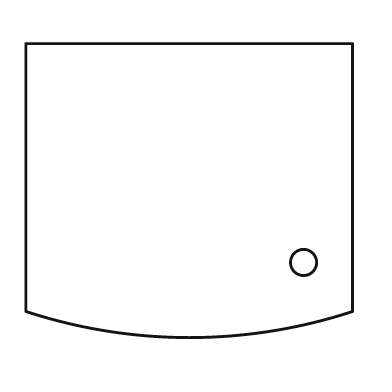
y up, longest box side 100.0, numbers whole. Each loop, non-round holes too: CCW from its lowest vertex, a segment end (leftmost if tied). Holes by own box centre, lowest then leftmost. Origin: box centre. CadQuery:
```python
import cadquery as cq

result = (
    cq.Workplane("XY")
    .moveTo(-50.0, -37.0)
    .threePointArc((0.0, -45.0), (50.0, -37.0))
    .lineTo(50.0, 45.0)
    .lineTo(-50.0, 45.0)
    .close()
    .moveTo(35.0, -22.0)
    .circle(4.0)
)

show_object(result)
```